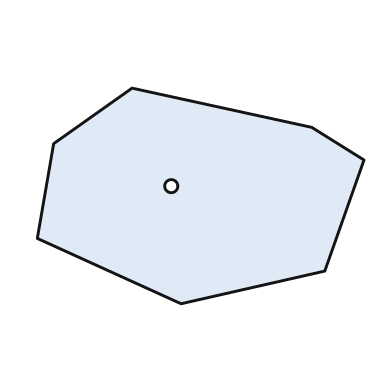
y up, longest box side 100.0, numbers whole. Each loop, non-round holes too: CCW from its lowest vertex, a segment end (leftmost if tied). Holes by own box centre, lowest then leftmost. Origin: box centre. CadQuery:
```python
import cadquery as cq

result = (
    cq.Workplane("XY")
    .moveTo(-6.0, -33.0)
    .lineTo(38.0, -23.0)
    .lineTo(50.0, 11.0)
    .lineTo(34.0, 21.0)
    .lineTo(-21.0, 33.0)
    .lineTo(-45.0, 16.0)
    .lineTo(-50.0, -13.0)
    .close()
    .moveTo(-9.0, 3.0)
    .circle(2.0)
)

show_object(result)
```